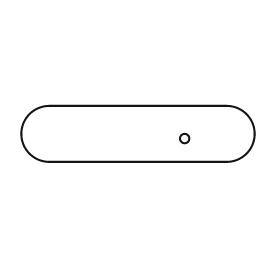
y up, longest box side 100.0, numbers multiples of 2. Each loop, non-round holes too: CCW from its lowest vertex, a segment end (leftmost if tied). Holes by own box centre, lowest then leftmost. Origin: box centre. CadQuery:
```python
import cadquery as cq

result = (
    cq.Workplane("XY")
    .moveTo(-38.0, -12.0)
    .lineTo(38.0, -12.0)
    .threePointArc((50.0, 0.0), (38.0, 12.0))
    .lineTo(-38.0, 12.0)
    .threePointArc((-50.0, 0.0), (-38.0, -12.0))
    .close()
    .moveTo(20.0, -2.0)
    .circle(2.0)
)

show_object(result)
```